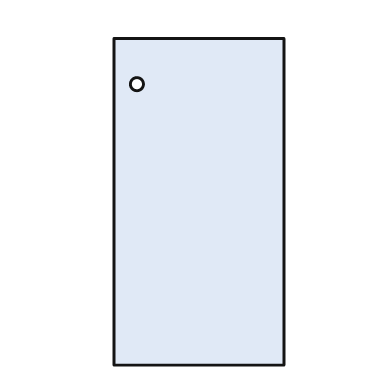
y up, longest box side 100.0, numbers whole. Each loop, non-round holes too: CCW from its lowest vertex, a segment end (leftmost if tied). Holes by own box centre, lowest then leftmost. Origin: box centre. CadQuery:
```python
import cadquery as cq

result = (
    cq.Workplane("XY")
    .moveTo(-26.0, -50.0)
    .lineTo(26.0, -50.0)
    .lineTo(26.0, 50.0)
    .lineTo(-26.0, 50.0)
    .close()
    .moveTo(-19.0, 36.0)
    .circle(2.0)
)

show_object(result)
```